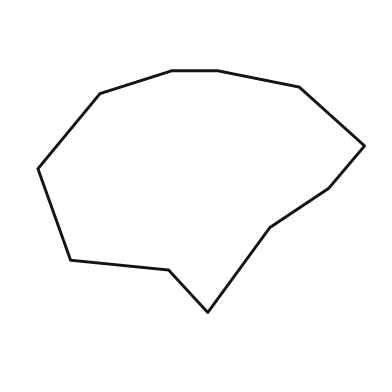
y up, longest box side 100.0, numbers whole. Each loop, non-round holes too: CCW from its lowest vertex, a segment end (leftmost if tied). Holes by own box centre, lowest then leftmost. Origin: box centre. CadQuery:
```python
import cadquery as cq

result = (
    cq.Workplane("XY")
    .moveTo(2.0, -37.0)
    .lineTo(21.0, -11.0)
    .lineTo(39.0, 1.0)
    .lineTo(50.0, 14.0)
    .lineTo(30.0, 32.0)
    .lineTo(5.0, 37.0)
    .lineTo(-9.0, 37.0)
    .lineTo(-31.0, 30.0)
    .lineTo(-50.0, 7.0)
    .lineTo(-40.0, -21.0)
    .lineTo(-10.0, -24.0)
    .close()
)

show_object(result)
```